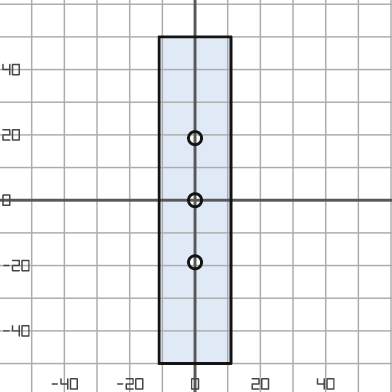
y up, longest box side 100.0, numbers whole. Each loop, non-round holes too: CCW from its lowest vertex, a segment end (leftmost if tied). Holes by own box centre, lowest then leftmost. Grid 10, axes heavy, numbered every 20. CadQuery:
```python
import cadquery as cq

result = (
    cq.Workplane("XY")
    .moveTo(-11.0, -50.0)
    .lineTo(11.0, -50.0)
    .lineTo(11.0, 50.0)
    .lineTo(-11.0, 50.0)
    .close()
    .moveTo(0.0, -19.0)
    .circle(2.0)
    .moveTo(0.0, 0.0)
    .circle(2.0)
    .moveTo(0.0, 19.0)
    .circle(2.0)
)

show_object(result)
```